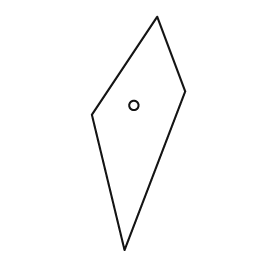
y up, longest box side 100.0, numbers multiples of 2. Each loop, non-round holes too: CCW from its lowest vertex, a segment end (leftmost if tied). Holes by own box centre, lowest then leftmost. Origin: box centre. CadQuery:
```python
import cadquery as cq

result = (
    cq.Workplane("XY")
    .moveTo(-6.0, -50.0)
    .lineTo(20.0, 18.0)
    .lineTo(8.0, 50.0)
    .lineTo(-20.0, 8.0)
    .close()
    .moveTo(-2.0, 12.0)
    .circle(2.0)
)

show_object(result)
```